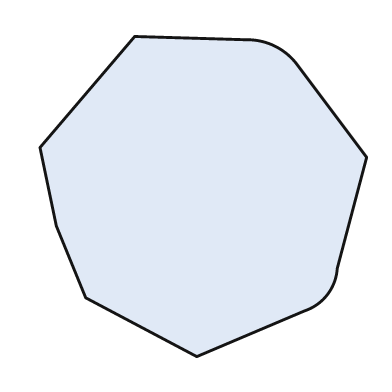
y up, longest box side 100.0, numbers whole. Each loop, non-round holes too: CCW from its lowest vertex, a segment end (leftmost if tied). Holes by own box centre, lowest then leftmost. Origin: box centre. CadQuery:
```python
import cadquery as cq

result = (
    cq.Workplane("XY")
    .moveTo(-2.0, -49.0)
    .lineTo(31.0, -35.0)
    .threePointArc((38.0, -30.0), (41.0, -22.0))
    .lineTo(50.0, 12.0)
    .lineTo(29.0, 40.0)
    .threePointArc((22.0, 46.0), (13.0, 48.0))
    .lineTo(-21.0, 49.0)
    .lineTo(-50.0, 15.0)
    .lineTo(-45.0, -9.0)
    .lineTo(-36.0, -31.0)
    .close()
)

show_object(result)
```